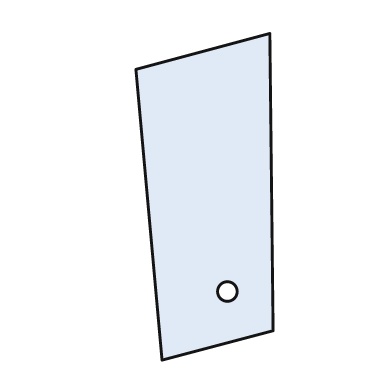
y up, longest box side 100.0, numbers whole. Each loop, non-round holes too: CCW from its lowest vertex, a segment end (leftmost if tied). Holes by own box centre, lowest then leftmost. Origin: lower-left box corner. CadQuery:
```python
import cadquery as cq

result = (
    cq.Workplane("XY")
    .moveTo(8.0, 0.0)
    .lineTo(42.0, 9.0)
    .lineTo(41.0, 100.0)
    .lineTo(0.0, 89.0)
    .close()
    .moveTo(28.0, 21.0)
    .circle(3.0)
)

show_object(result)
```